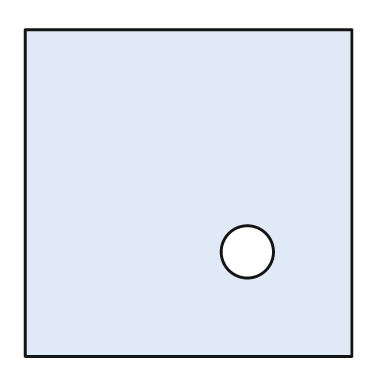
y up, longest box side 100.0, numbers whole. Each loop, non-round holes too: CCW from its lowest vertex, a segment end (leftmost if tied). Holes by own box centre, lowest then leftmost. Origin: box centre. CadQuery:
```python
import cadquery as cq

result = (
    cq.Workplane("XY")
    .moveTo(-50.0, -50.0)
    .lineTo(50.0, -50.0)
    .lineTo(50.0, 50.0)
    .lineTo(-50.0, 50.0)
    .close()
    .moveTo(18.0, -18.0)
    .circle(8.0)
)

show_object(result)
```